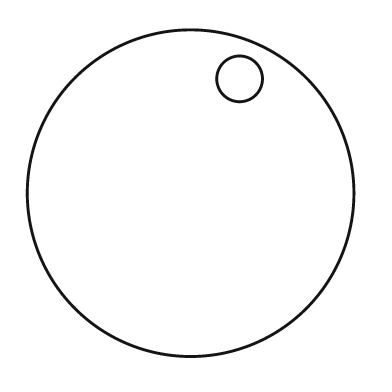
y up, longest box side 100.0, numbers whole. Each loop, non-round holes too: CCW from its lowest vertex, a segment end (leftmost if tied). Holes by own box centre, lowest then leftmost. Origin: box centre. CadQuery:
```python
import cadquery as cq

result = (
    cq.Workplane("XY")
    .moveTo(0.0, 0.0)
    .circle(50.0)
    .moveTo(15.0, 35.0)
    .circle(7.0)
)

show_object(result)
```